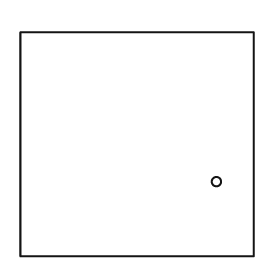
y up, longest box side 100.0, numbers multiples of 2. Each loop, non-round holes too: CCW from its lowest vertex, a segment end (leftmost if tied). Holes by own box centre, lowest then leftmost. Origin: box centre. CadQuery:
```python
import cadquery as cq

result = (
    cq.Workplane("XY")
    .moveTo(-50.0, -48.0)
    .lineTo(50.0, -48.0)
    .lineTo(50.0, 48.0)
    .lineTo(-50.0, 48.0)
    .close()
    .moveTo(34.0, -16.0)
    .circle(2.0)
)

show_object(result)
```